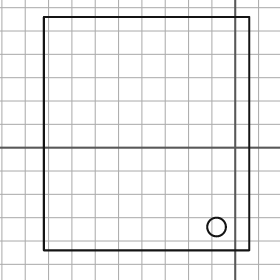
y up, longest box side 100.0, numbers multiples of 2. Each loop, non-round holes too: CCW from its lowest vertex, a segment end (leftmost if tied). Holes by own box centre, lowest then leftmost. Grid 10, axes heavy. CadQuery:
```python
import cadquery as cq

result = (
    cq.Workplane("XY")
    .moveTo(-82.0, -44.0)
    .lineTo(6.0, -44.0)
    .lineTo(6.0, 56.0)
    .lineTo(-82.0, 56.0)
    .close()
    .moveTo(-8.0, -34.0)
    .circle(4.0)
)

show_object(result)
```